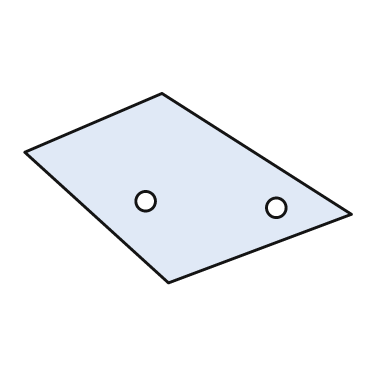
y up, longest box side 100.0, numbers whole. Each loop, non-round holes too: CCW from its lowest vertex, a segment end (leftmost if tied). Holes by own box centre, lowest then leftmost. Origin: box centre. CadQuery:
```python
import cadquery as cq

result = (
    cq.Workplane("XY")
    .moveTo(-6.0, -29.0)
    .lineTo(50.0, -8.0)
    .lineTo(-8.0, 29.0)
    .lineTo(-50.0, 11.0)
    .close()
    .moveTo(27.0, -6.0)
    .circle(3.0)
    .moveTo(-13.0, -4.0)
    .circle(3.0)
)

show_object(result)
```